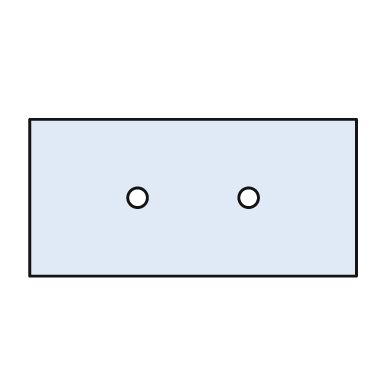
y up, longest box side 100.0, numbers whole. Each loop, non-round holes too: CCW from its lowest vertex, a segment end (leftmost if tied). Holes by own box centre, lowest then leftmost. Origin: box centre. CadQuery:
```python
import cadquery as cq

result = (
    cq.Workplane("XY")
    .moveTo(-50.0, -24.0)
    .lineTo(50.0, -24.0)
    .lineTo(50.0, 24.0)
    .lineTo(-50.0, 24.0)
    .close()
    .moveTo(-17.0, 0.0)
    .circle(3.0)
    .moveTo(17.0, 0.0)
    .circle(3.0)
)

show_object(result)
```